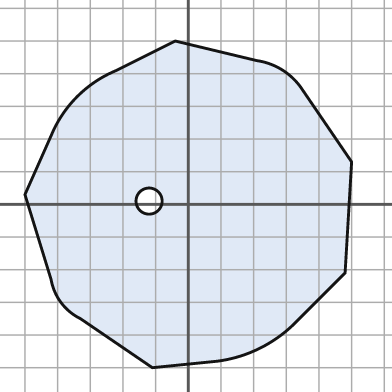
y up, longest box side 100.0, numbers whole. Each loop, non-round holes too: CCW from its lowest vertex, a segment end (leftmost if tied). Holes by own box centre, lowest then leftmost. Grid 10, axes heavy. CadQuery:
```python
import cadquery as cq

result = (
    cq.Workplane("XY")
    .moveTo(-11.0, -50.0)
    .lineTo(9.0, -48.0)
    .threePointArc((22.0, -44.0), (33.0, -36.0))
    .lineTo(48.0, -21.0)
    .lineTo(50.0, 13.0)
    .lineTo(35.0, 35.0)
    .threePointArc((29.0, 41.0), (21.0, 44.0))
    .lineTo(-4.0, 50.0)
    .lineTo(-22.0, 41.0)
    .threePointArc((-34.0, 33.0), (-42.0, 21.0))
    .lineTo(-50.0, 3.0)
    .lineTo(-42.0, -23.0)
    .threePointArc((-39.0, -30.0), (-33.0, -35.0))
    .close()
    .moveTo(-12.0, 1.0)
    .circle(4.0)
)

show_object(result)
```